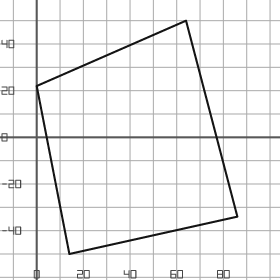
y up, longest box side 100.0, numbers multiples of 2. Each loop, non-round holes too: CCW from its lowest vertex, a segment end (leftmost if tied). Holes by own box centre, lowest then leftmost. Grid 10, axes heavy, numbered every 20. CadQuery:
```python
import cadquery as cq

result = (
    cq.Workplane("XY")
    .moveTo(14.0, -50.0)
    .lineTo(86.0, -34.0)
    .lineTo(64.0, 50.0)
    .lineTo(0.0, 22.0)
    .close()
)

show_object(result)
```